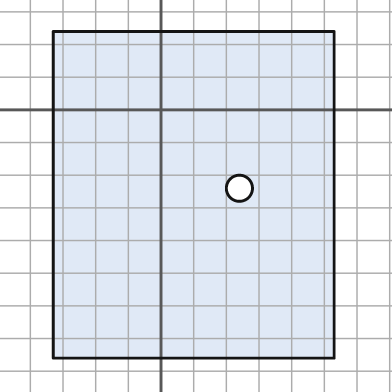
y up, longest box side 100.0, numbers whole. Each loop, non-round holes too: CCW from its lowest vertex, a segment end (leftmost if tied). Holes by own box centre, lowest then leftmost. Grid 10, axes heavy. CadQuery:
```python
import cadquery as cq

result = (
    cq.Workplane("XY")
    .moveTo(-33.0, -76.0)
    .lineTo(53.0, -76.0)
    .lineTo(53.0, 24.0)
    .lineTo(-33.0, 24.0)
    .close()
    .moveTo(24.0, -24.0)
    .circle(4.0)
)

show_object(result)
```